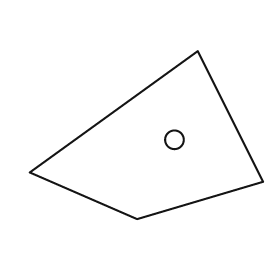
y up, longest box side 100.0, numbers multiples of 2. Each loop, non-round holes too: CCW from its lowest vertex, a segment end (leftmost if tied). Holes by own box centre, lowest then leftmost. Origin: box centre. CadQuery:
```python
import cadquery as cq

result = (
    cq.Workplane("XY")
    .moveTo(-4.0, -36.0)
    .lineTo(50.0, -20.0)
    .lineTo(22.0, 36.0)
    .lineTo(-50.0, -16.0)
    .close()
    .moveTo(12.0, -2.0)
    .circle(4.0)
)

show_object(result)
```